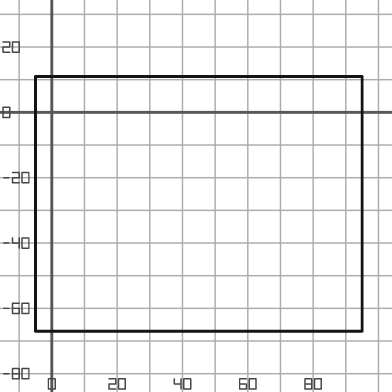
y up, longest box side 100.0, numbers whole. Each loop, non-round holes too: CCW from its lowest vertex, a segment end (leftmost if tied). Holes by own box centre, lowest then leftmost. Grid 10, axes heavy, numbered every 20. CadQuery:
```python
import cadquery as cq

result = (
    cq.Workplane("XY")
    .moveTo(-5.0, -67.0)
    .lineTo(95.0, -67.0)
    .lineTo(95.0, 11.0)
    .lineTo(-5.0, 11.0)
    .close()
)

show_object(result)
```